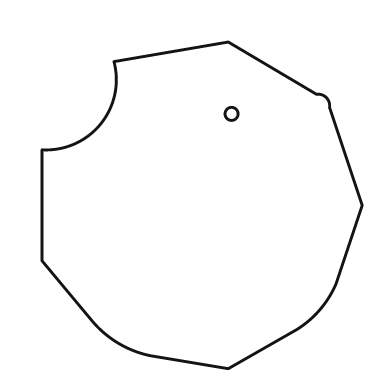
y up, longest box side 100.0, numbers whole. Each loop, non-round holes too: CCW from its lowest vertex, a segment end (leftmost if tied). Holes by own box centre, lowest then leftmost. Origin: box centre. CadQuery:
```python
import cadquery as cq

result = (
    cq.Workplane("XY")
    .moveTo(8.0, -50.0)
    .lineTo(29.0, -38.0)
    .threePointArc((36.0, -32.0), (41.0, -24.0))
    .lineTo(49.0, 0.0)
    .lineTo(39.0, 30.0)
    .threePointArc((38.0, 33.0), (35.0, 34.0))
    .lineTo(8.0, 50.0)
    .lineTo(-27.0, 44.0)
    .threePointArc((-31.0, 25.0), (-49.0, 17.0))
    .lineTo(-49.0, -17.0)
    .lineTo(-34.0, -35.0)
    .threePointArc((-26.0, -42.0), (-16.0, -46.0))
    .close()
    .moveTo(9.0, 28.0)
    .circle(2.0)
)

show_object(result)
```